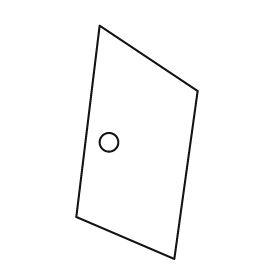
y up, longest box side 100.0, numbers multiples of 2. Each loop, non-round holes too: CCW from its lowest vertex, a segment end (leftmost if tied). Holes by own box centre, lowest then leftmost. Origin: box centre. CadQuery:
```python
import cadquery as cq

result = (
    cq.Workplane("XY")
    .moveTo(16.0, -50.0)
    .lineTo(26.0, 22.0)
    .lineTo(-16.0, 50.0)
    .lineTo(-26.0, -32.0)
    .close()
    .moveTo(-12.0, 0.0)
    .circle(4.0)
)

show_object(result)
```